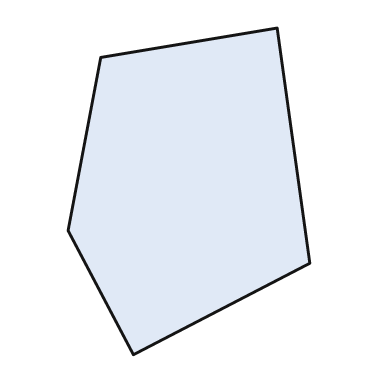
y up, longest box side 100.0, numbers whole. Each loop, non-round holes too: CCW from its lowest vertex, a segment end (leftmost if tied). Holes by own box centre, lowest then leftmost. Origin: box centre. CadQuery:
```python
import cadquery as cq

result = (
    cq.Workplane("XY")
    .moveTo(-17.0, -50.0)
    .lineTo(37.0, -22.0)
    .lineTo(27.0, 50.0)
    .lineTo(-27.0, 41.0)
    .lineTo(-37.0, -12.0)
    .close()
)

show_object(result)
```